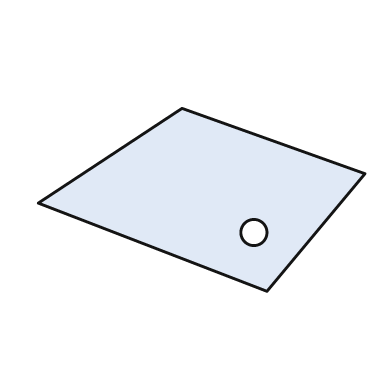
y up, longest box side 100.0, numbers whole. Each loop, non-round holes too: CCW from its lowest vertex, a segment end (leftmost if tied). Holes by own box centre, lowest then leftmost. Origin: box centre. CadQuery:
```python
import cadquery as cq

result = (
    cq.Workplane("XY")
    .moveTo(20.0, -28.0)
    .lineTo(50.0, 8.0)
    .lineTo(-6.0, 28.0)
    .lineTo(-50.0, -1.0)
    .close()
    .moveTo(16.0, -10.0)
    .circle(4.0)
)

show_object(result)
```